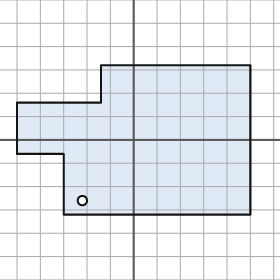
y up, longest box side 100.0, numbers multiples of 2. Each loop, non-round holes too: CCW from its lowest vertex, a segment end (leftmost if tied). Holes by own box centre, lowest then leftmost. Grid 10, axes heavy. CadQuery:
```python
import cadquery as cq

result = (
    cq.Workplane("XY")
    .moveTo(-30.0, -32.0)
    .lineTo(50.0, -32.0)
    .lineTo(50.0, 32.0)
    .lineTo(-14.0, 32.0)
    .lineTo(-14.0, 16.0)
    .lineTo(-50.0, 16.0)
    .lineTo(-50.0, -6.0)
    .lineTo(-30.0, -6.0)
    .close()
    .moveTo(-22.0, -26.0)
    .circle(2.0)
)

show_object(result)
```